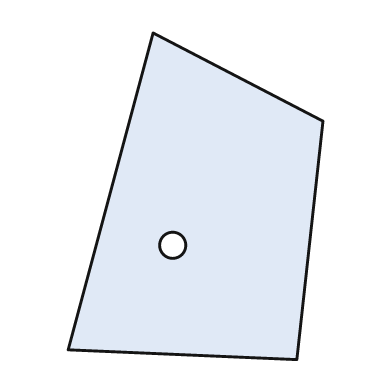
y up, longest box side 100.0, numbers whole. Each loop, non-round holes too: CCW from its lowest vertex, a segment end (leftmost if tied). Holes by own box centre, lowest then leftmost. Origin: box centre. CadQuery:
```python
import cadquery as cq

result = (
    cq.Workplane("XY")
    .moveTo(31.0, -50.0)
    .lineTo(39.0, 23.0)
    .lineTo(-13.0, 50.0)
    .lineTo(-39.0, -47.0)
    .close()
    .moveTo(-7.0, -15.0)
    .circle(4.0)
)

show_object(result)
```